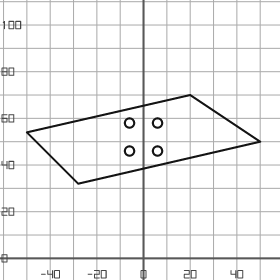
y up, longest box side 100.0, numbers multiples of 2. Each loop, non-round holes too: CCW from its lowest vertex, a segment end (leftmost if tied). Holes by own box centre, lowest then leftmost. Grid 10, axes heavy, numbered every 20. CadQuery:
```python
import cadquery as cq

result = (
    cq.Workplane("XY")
    .moveTo(-28.0, 32.0)
    .lineTo(50.0, 50.0)
    .lineTo(20.0, 70.0)
    .lineTo(-50.0, 54.0)
    .close()
    .moveTo(-6.0, 46.0)
    .circle(2.0)
    .moveTo(6.0, 46.0)
    .circle(2.0)
    .moveTo(-6.0, 58.0)
    .circle(2.0)
    .moveTo(6.0, 58.0)
    .circle(2.0)
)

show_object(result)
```